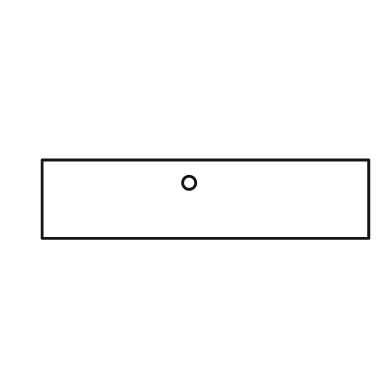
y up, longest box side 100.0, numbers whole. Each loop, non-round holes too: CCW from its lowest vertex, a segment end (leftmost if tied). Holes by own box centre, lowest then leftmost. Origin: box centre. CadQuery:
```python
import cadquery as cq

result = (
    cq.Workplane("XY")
    .moveTo(-50.0, -12.0)
    .lineTo(50.0, -12.0)
    .lineTo(50.0, 12.0)
    .lineTo(-50.0, 12.0)
    .close()
    .moveTo(-5.0, 5.0)
    .circle(2.0)
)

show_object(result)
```